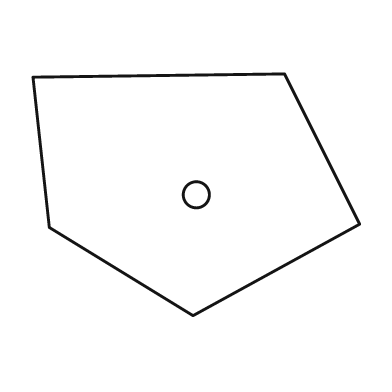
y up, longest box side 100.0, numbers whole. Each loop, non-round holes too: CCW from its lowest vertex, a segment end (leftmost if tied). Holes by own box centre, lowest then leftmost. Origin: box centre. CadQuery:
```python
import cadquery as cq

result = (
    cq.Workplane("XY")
    .moveTo(-1.0, -37.0)
    .lineTo(50.0, -9.0)
    .lineTo(27.0, 37.0)
    .lineTo(-50.0, 36.0)
    .lineTo(-45.0, -10.0)
    .close()
    .moveTo(0.0, 0.0)
    .circle(4.0)
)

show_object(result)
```